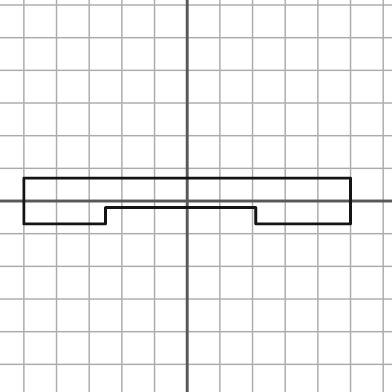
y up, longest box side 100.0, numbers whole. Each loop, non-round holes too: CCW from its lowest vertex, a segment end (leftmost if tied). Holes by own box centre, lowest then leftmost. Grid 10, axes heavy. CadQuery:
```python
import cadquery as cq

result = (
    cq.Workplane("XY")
    .moveTo(-50.0, -7.0)
    .lineTo(-25.0, -7.0)
    .lineTo(-25.0, -2.0)
    .lineTo(21.0, -2.0)
    .lineTo(21.0, -7.0)
    .lineTo(50.0, -7.0)
    .lineTo(50.0, 7.0)
    .lineTo(-50.0, 7.0)
    .close()
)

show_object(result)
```